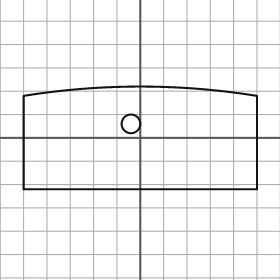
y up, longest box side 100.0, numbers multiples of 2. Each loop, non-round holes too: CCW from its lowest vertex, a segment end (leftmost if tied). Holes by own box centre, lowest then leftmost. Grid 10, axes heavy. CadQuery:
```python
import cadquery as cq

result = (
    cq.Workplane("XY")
    .moveTo(-50.0, -22.0)
    .lineTo(50.0, -22.0)
    .lineTo(50.0, 18.0)
    .threePointArc((0.0, 22.0), (-50.0, 18.0))
    .close()
    .moveTo(-4.0, 6.0)
    .circle(4.0)
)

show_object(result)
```